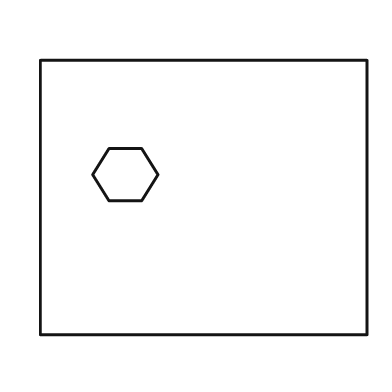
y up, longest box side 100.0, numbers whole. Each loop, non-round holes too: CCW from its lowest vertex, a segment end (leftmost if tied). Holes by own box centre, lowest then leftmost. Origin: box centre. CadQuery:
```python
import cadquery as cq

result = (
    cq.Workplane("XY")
    .moveTo(-50.0, -42.0)
    .lineTo(50.0, -42.0)
    .lineTo(50.0, 42.0)
    .lineTo(-50.0, 42.0)
    .close()
    .moveTo(-29.0, -1.0)
    .lineTo(-19.0, -1.0)
    .lineTo(-14.0, 7.0)
    .lineTo(-19.0, 15.0)
    .lineTo(-29.0, 15.0)
    .lineTo(-34.0, 7.0)
    .close()
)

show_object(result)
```